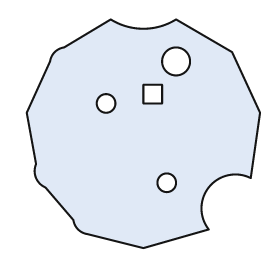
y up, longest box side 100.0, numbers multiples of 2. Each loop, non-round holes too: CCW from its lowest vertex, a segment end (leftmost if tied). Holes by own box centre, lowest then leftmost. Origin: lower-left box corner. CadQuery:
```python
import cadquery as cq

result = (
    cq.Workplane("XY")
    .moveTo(50.0, 0.0)
    .lineTo(78.0, 8.0)
    .threePointArc((78.0, 26.0), (96.0, 30.0))
    .lineTo(100.0, 58.0)
    .lineTo(88.0, 84.0)
    .lineTo(64.0, 98.0)
    .threePointArc((50.0, 94.0), (36.0, 98.0))
    .lineTo(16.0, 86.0)
    .threePointArc((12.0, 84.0), (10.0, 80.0))
    .lineTo(0.0, 58.0)
    .lineTo(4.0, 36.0)
    .threePointArc((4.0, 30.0), (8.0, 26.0))
    .lineTo(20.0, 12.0)
    .threePointArc((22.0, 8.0), (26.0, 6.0))
    .close()
    .moveTo(60.0, 28.0)
    .circle(4.0)
    .moveTo(34.0, 62.0)
    .circle(4.0)
    .moveTo(50.0, 62.0)
    .lineTo(58.0, 62.0)
    .lineTo(58.0, 70.0)
    .lineTo(50.0, 70.0)
    .close()
    .moveTo(64.0, 80.0)
    .circle(6.0)
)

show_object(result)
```